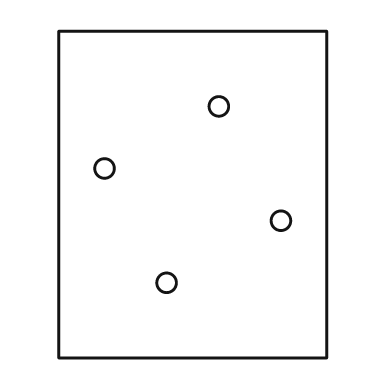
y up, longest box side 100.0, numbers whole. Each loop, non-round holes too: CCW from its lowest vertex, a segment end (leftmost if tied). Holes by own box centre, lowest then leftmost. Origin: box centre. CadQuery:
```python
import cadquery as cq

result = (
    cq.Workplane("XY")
    .moveTo(-41.0, -50.0)
    .lineTo(41.0, -50.0)
    .lineTo(41.0, 50.0)
    .lineTo(-41.0, 50.0)
    .close()
    .moveTo(-8.0, -27.0)
    .circle(3.0)
    .moveTo(27.0, -8.0)
    .circle(3.0)
    .moveTo(-27.0, 8.0)
    .circle(3.0)
    .moveTo(8.0, 27.0)
    .circle(3.0)
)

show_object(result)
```